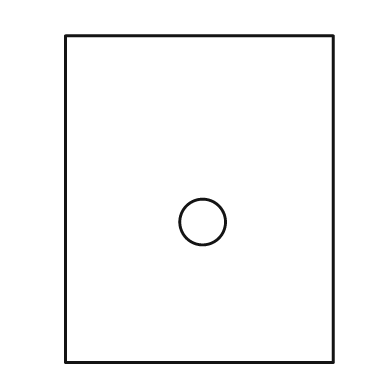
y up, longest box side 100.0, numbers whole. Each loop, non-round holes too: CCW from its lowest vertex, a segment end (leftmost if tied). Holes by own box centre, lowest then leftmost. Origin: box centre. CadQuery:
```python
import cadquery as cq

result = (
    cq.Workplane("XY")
    .moveTo(-41.0, -50.0)
    .lineTo(41.0, -50.0)
    .lineTo(41.0, 50.0)
    .lineTo(-41.0, 50.0)
    .close()
    .moveTo(1.0, -7.0)
    .circle(7.0)
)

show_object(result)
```